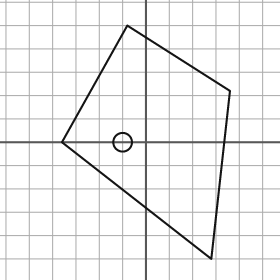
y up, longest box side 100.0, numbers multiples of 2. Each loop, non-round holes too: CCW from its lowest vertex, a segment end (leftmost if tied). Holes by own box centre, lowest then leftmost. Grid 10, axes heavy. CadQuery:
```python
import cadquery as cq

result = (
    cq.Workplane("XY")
    .moveTo(28.0, -50.0)
    .lineTo(36.0, 22.0)
    .lineTo(-8.0, 50.0)
    .lineTo(-36.0, 0.0)
    .close()
    .moveTo(-10.0, 0.0)
    .circle(4.0)
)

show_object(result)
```